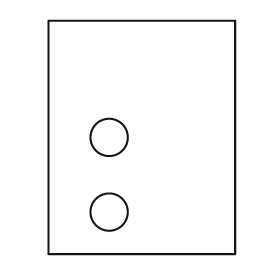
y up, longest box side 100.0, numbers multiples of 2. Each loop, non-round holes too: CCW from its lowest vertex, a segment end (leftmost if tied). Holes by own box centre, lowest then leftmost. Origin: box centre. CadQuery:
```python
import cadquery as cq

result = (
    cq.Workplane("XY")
    .moveTo(-40.0, -50.0)
    .lineTo(40.0, -50.0)
    .lineTo(40.0, 50.0)
    .lineTo(-40.0, 50.0)
    .close()
    .moveTo(-14.0, -32.0)
    .circle(8.0)
    .moveTo(-14.0, 0.0)
    .circle(8.0)
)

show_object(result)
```